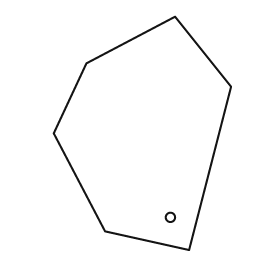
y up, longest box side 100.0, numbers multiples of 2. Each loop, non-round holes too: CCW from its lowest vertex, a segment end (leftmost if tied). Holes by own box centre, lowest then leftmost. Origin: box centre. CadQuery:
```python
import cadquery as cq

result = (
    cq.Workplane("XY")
    .moveTo(20.0, -50.0)
    .lineTo(38.0, 20.0)
    .lineTo(14.0, 50.0)
    .lineTo(-24.0, 30.0)
    .lineTo(-38.0, 0.0)
    .lineTo(-16.0, -42.0)
    .close()
    .moveTo(12.0, -36.0)
    .circle(2.0)
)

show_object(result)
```